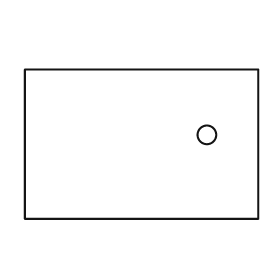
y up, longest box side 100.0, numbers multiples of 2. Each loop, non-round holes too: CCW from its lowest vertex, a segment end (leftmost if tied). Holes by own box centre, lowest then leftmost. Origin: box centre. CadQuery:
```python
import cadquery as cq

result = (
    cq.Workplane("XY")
    .moveTo(-50.0, -32.0)
    .lineTo(50.0, -32.0)
    .lineTo(50.0, 32.0)
    .lineTo(-50.0, 32.0)
    .close()
    .moveTo(28.0, 4.0)
    .circle(4.0)
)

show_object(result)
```